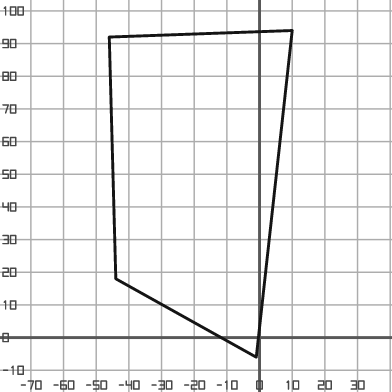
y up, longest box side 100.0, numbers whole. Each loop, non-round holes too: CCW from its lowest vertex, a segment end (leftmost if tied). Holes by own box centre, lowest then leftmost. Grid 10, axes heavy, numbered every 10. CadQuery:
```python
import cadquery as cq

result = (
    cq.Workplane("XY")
    .moveTo(-1.0, -6.0)
    .lineTo(10.0, 94.0)
    .lineTo(-46.0, 92.0)
    .lineTo(-44.0, 18.0)
    .close()
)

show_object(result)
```